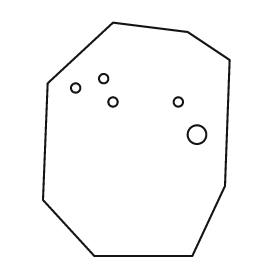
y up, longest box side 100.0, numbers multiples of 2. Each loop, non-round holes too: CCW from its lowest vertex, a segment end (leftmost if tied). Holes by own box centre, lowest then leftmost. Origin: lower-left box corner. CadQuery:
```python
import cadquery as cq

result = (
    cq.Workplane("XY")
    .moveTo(22.0, 0.0)
    .lineTo(64.0, 0.0)
    .lineTo(78.0, 30.0)
    .lineTo(80.0, 84.0)
    .lineTo(62.0, 96.0)
    .lineTo(30.0, 100.0)
    .lineTo(2.0, 74.0)
    .lineTo(0.0, 24.0)
    .close()
    .moveTo(66.0, 52.0)
    .circle(4.0)
    .moveTo(30.0, 66.0)
    .circle(2.0)
    .moveTo(58.0, 66.0)
    .circle(2.0)
    .moveTo(14.0, 72.0)
    .circle(2.0)
    .moveTo(26.0, 76.0)
    .circle(2.0)
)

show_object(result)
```